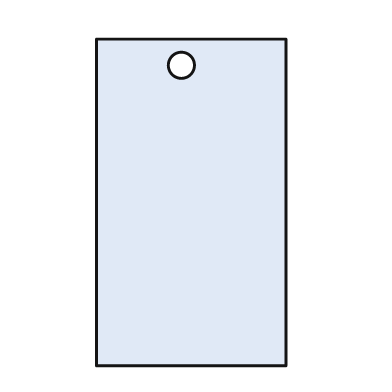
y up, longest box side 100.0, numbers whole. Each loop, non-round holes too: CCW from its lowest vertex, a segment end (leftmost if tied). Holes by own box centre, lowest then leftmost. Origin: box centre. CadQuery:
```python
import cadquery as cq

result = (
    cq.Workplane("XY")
    .moveTo(-29.0, -50.0)
    .lineTo(29.0, -50.0)
    .lineTo(29.0, 50.0)
    .lineTo(-29.0, 50.0)
    .close()
    .moveTo(-3.0, 42.0)
    .circle(4.0)
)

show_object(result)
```